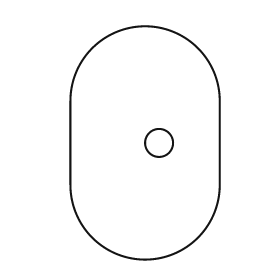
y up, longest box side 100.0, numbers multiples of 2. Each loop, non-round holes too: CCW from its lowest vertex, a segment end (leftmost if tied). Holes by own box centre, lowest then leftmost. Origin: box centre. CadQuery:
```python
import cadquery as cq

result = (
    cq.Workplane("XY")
    .moveTo(-32.0, -18.0)
    .threePointArc((0.0, -50.0), (32.0, -18.0))
    .lineTo(32.0, 18.0)
    .threePointArc((0.0, 50.0), (-32.0, 18.0))
    .close()
    .moveTo(6.0, 0.0)
    .circle(6.0)
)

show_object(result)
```